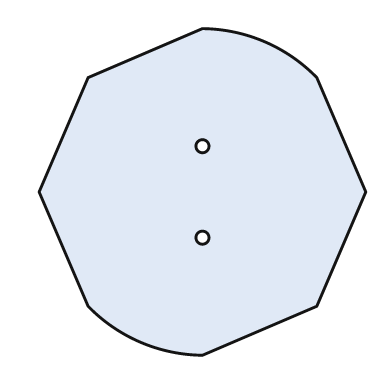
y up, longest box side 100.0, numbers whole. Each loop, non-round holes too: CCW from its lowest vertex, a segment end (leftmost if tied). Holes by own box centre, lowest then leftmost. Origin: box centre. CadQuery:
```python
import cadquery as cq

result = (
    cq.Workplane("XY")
    .moveTo(0.0, -50.0)
    .lineTo(35.0, -35.0)
    .lineTo(50.0, 0.0)
    .lineTo(35.0, 35.0)
    .threePointArc((19.0, 46.0), (0.0, 50.0))
    .lineTo(-35.0, 35.0)
    .lineTo(-50.0, 0.0)
    .lineTo(-35.0, -35.0)
    .threePointArc((-19.0, -46.0), (0.0, -50.0))
    .close()
    .moveTo(0.0, -14.0)
    .circle(2.0)
    .moveTo(0.0, 14.0)
    .circle(2.0)
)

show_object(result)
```